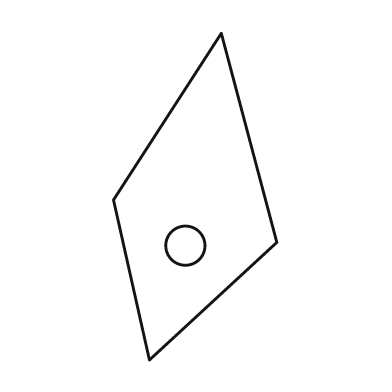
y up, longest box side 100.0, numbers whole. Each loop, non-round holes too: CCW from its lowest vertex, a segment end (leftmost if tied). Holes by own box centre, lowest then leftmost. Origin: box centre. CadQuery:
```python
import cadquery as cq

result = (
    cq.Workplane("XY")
    .moveTo(-14.0, -50.0)
    .lineTo(25.0, -14.0)
    .lineTo(8.0, 50.0)
    .lineTo(-25.0, -1.0)
    .close()
    .moveTo(-3.0, -15.0)
    .circle(6.0)
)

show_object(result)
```